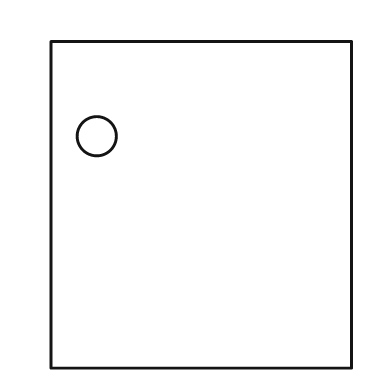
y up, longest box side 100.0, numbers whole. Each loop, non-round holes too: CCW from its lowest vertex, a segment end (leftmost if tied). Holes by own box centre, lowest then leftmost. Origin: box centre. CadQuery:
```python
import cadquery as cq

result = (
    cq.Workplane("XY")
    .moveTo(-46.0, -50.0)
    .lineTo(46.0, -50.0)
    .lineTo(46.0, 50.0)
    .lineTo(-46.0, 50.0)
    .close()
    .moveTo(-32.0, 21.0)
    .circle(6.0)
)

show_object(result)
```